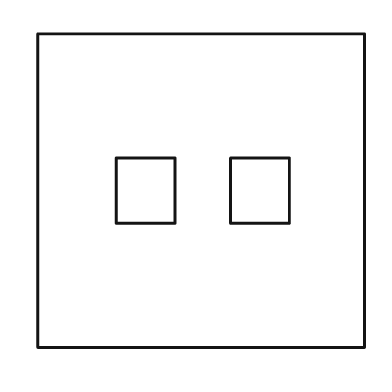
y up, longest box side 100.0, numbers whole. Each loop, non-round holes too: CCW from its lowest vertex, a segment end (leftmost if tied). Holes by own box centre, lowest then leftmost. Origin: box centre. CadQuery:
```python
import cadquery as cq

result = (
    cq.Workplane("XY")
    .moveTo(-50.0, -48.0)
    .lineTo(50.0, -48.0)
    .lineTo(50.0, 48.0)
    .lineTo(-50.0, 48.0)
    .close()
    .moveTo(-26.0, -10.0)
    .lineTo(-8.0, -10.0)
    .lineTo(-8.0, 10.0)
    .lineTo(-26.0, 10.0)
    .close()
    .moveTo(9.0, -10.0)
    .lineTo(27.0, -10.0)
    .lineTo(27.0, 10.0)
    .lineTo(9.0, 10.0)
    .close()
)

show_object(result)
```